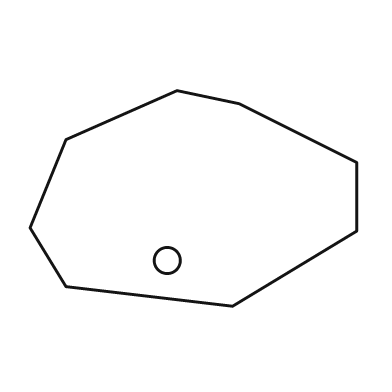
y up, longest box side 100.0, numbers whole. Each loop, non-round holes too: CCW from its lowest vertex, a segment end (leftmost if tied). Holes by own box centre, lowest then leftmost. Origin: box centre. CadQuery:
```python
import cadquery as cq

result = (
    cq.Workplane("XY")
    .moveTo(12.0, -33.0)
    .lineTo(50.0, -10.0)
    .lineTo(50.0, 11.0)
    .lineTo(14.0, 29.0)
    .lineTo(-5.0, 33.0)
    .lineTo(-39.0, 18.0)
    .lineTo(-50.0, -9.0)
    .lineTo(-39.0, -27.0)
    .close()
    .moveTo(-8.0, -19.0)
    .circle(4.0)
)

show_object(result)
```